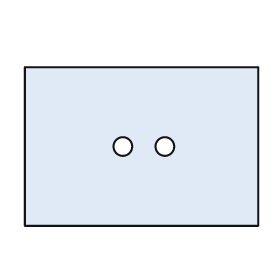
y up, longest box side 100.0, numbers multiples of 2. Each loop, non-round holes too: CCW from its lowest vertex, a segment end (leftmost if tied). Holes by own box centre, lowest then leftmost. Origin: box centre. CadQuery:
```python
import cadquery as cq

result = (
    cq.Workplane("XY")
    .moveTo(-50.0, -34.0)
    .lineTo(50.0, -34.0)
    .lineTo(50.0, 34.0)
    .lineTo(-50.0, 34.0)
    .close()
    .moveTo(-8.0, 0.0)
    .circle(4.0)
    .moveTo(10.0, 0.0)
    .circle(4.0)
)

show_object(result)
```